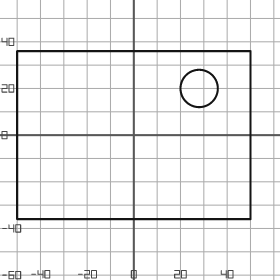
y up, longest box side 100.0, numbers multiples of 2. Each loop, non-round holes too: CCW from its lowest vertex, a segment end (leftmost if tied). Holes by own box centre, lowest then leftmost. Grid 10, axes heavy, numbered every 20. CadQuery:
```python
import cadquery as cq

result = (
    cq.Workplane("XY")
    .moveTo(-50.0, -36.0)
    .lineTo(50.0, -36.0)
    .lineTo(50.0, 36.0)
    .lineTo(-50.0, 36.0)
    .close()
    .moveTo(28.0, 20.0)
    .circle(8.0)
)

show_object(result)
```